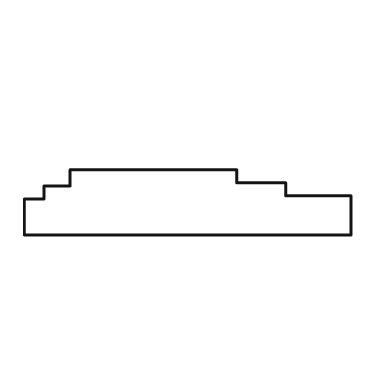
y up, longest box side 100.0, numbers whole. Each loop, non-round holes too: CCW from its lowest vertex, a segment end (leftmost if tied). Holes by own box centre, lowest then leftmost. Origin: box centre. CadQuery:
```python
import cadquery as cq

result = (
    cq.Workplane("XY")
    .moveTo(-50.0, -10.0)
    .lineTo(50.0, -10.0)
    .lineTo(50.0, 2.0)
    .lineTo(30.0, 2.0)
    .lineTo(30.0, 6.0)
    .lineTo(15.0, 6.0)
    .lineTo(15.0, 10.0)
    .lineTo(-36.0, 10.0)
    .lineTo(-36.0, 5.0)
    .lineTo(-44.0, 5.0)
    .lineTo(-44.0, 1.0)
    .lineTo(-50.0, 1.0)
    .close()
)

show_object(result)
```